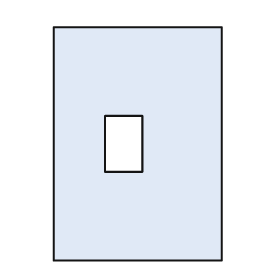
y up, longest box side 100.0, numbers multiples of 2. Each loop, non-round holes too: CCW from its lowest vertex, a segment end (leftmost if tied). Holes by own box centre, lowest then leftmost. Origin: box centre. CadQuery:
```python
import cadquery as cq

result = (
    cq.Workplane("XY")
    .moveTo(-36.0, -50.0)
    .lineTo(36.0, -50.0)
    .lineTo(36.0, 50.0)
    .lineTo(-36.0, 50.0)
    .close()
    .moveTo(-14.0, -12.0)
    .lineTo(2.0, -12.0)
    .lineTo(2.0, 12.0)
    .lineTo(-14.0, 12.0)
    .close()
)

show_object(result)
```